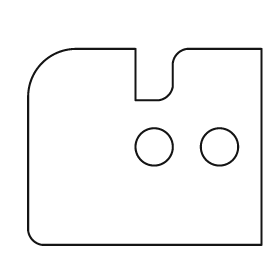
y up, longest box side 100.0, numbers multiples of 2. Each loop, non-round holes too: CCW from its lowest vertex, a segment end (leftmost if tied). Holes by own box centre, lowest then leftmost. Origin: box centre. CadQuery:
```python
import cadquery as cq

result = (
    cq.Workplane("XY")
    .moveTo(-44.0, -42.0)
    .lineTo(50.0, -42.0)
    .lineTo(50.0, 42.0)
    .lineTo(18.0, 42.0)
    .threePointArc((14.0, 40.0), (12.0, 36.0))
    .lineTo(12.0, 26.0)
    .threePointArc((10.0, 22.0), (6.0, 20.0))
    .lineTo(-4.0, 20.0)
    .lineTo(-4.0, 42.0)
    .lineTo(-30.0, 42.0)
    .threePointArc((-44.0, 36.0), (-50.0, 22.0))
    .lineTo(-50.0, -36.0)
    .threePointArc((-48.0, -40.0), (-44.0, -42.0))
    .close()
    .moveTo(4.0, 0.0)
    .circle(8.0)
    .moveTo(32.0, 0.0)
    .circle(8.0)
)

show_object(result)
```